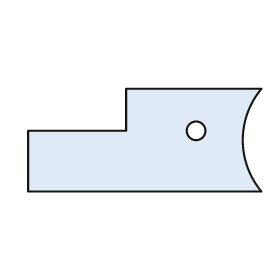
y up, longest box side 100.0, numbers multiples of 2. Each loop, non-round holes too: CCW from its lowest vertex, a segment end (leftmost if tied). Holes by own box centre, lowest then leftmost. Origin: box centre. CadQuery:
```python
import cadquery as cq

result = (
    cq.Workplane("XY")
    .moveTo(-50.0, -22.0)
    .lineTo(50.0, -22.0)
    .threePointArc((42.0, 0.0), (50.0, 22.0))
    .lineTo(-8.0, 22.0)
    .lineTo(-8.0, 4.0)
    .lineTo(-50.0, 4.0)
    .close()
    .moveTo(22.0, 4.0)
    .circle(4.0)
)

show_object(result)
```